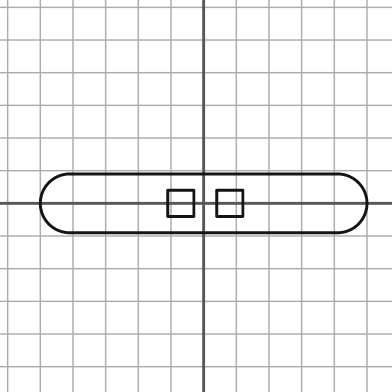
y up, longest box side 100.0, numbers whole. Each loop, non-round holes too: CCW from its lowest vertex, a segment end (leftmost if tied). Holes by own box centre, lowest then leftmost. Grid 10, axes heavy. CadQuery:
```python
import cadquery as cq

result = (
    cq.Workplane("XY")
    .moveTo(-41.0, -9.0)
    .lineTo(41.0, -9.0)
    .threePointArc((50.0, 0.0), (41.0, 9.0))
    .lineTo(-41.0, 9.0)
    .threePointArc((-50.0, 0.0), (-41.0, -9.0))
    .close()
    .moveTo(-11.0, -4.0)
    .lineTo(-3.0, -4.0)
    .lineTo(-3.0, 4.0)
    .lineTo(-11.0, 4.0)
    .close()
    .moveTo(4.0, -4.0)
    .lineTo(12.0, -4.0)
    .lineTo(12.0, 4.0)
    .lineTo(4.0, 4.0)
    .close()
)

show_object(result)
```